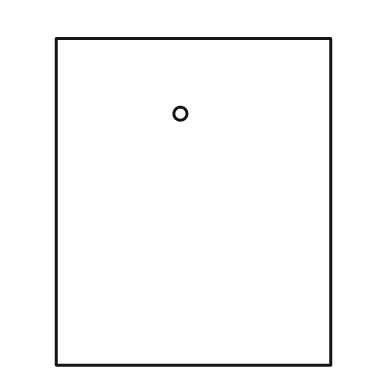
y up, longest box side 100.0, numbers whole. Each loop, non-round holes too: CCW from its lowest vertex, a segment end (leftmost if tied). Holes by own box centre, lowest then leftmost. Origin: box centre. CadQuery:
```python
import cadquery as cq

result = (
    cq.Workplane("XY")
    .moveTo(-42.0, -50.0)
    .lineTo(42.0, -50.0)
    .lineTo(42.0, 50.0)
    .lineTo(-42.0, 50.0)
    .close()
    .moveTo(-4.0, 27.0)
    .circle(2.0)
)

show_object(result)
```